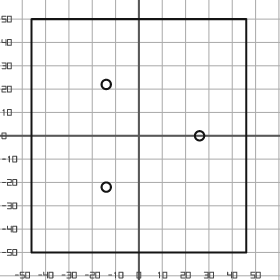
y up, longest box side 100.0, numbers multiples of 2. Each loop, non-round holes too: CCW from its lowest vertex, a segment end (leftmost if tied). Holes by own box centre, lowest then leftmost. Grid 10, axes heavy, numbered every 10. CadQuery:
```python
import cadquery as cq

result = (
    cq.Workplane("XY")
    .moveTo(-46.0, -50.0)
    .lineTo(46.0, -50.0)
    .lineTo(46.0, 50.0)
    .lineTo(-46.0, 50.0)
    .close()
    .moveTo(-14.0, -22.0)
    .circle(2.0)
    .moveTo(26.0, 0.0)
    .circle(2.0)
    .moveTo(-14.0, 22.0)
    .circle(2.0)
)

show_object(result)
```